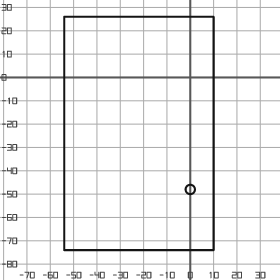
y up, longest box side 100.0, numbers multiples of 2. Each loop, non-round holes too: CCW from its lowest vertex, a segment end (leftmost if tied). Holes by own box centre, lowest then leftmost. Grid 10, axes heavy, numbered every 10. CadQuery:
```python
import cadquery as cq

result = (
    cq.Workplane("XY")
    .moveTo(-54.0, -74.0)
    .lineTo(10.0, -74.0)
    .lineTo(10.0, 26.0)
    .lineTo(-54.0, 26.0)
    .close()
    .moveTo(0.0, -48.0)
    .circle(2.0)
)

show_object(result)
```